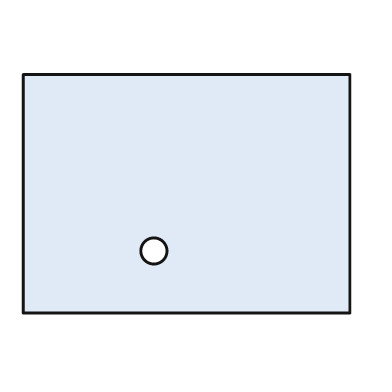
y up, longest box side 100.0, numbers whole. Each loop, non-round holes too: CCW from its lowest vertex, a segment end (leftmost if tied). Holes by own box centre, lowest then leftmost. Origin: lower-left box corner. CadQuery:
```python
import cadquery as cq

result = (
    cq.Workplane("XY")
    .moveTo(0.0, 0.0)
    .lineTo(100.0, 0.0)
    .lineTo(100.0, 73.0)
    .lineTo(0.0, 73.0)
    .close()
    .moveTo(40.0, 19.0)
    .circle(4.0)
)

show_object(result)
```